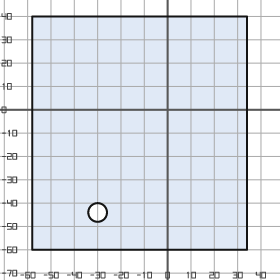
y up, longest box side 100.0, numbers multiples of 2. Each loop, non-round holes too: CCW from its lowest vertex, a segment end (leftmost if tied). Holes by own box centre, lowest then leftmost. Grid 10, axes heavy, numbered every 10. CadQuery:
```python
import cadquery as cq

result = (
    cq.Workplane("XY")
    .moveTo(-58.0, -60.0)
    .lineTo(34.0, -60.0)
    .lineTo(34.0, 40.0)
    .lineTo(-58.0, 40.0)
    .close()
    .moveTo(-30.0, -44.0)
    .circle(4.0)
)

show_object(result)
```